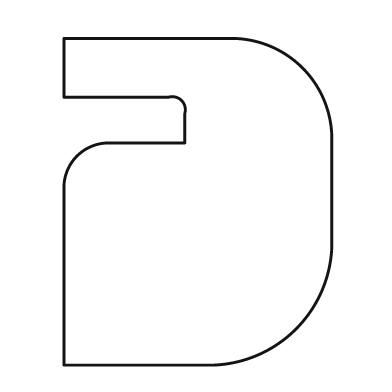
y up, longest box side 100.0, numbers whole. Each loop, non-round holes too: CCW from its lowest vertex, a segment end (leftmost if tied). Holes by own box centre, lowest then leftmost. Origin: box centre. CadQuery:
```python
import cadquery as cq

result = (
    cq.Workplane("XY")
    .moveTo(-41.0, -50.0)
    .lineTo(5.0, -50.0)
    .threePointArc((30.0, -39.0), (41.0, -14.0))
    .lineTo(41.0, 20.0)
    .threePointArc((32.0, 41.0), (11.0, 50.0))
    .lineTo(-41.0, 50.0)
    .lineTo(-41.0, 32.0)
    .lineTo(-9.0, 32.0)
    .threePointArc((-5.0, 31.0), (-4.0, 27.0))
    .lineTo(-4.0, 18.0)
    .lineTo(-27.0, 18.0)
    .threePointArc((-37.0, 14.0), (-41.0, 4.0))
    .close()
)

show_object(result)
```